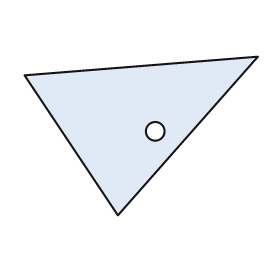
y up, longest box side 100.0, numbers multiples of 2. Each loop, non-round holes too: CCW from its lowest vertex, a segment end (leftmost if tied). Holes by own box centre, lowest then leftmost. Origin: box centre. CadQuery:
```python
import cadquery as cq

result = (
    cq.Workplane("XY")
    .moveTo(-10.0, -34.0)
    .lineTo(50.0, 34.0)
    .lineTo(-50.0, 26.0)
    .close()
    .moveTo(6.0, 2.0)
    .circle(4.0)
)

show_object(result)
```